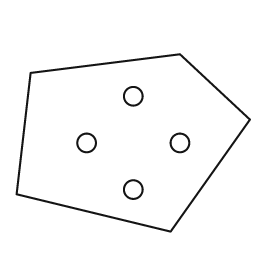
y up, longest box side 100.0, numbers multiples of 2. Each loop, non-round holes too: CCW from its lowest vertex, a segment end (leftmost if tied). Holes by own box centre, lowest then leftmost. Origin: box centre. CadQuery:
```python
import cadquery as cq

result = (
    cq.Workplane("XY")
    .moveTo(16.0, -38.0)
    .lineTo(50.0, 10.0)
    .lineTo(20.0, 38.0)
    .lineTo(-44.0, 30.0)
    .lineTo(-50.0, -22.0)
    .close()
    .moveTo(0.0, -20.0)
    .circle(4.0)
    .moveTo(-20.0, 0.0)
    .circle(4.0)
    .moveTo(20.0, 0.0)
    .circle(4.0)
    .moveTo(0.0, 20.0)
    .circle(4.0)
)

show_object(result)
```